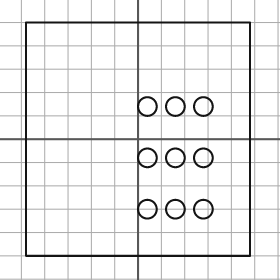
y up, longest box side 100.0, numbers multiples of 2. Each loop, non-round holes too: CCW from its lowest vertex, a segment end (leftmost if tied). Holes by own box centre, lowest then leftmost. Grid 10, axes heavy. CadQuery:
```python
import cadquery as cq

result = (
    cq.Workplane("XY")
    .moveTo(-48.0, -50.0)
    .lineTo(48.0, -50.0)
    .lineTo(48.0, 50.0)
    .lineTo(-48.0, 50.0)
    .close()
    .moveTo(4.0, -30.0)
    .circle(4.0)
    .moveTo(16.0, -30.0)
    .circle(4.0)
    .moveTo(28.0, -30.0)
    .circle(4.0)
    .moveTo(4.0, -8.0)
    .circle(4.0)
    .moveTo(16.0, -8.0)
    .circle(4.0)
    .moveTo(28.0, -8.0)
    .circle(4.0)
    .moveTo(4.0, 14.0)
    .circle(4.0)
    .moveTo(16.0, 14.0)
    .circle(4.0)
    .moveTo(28.0, 14.0)
    .circle(4.0)
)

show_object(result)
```